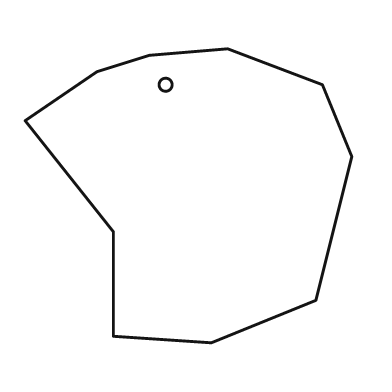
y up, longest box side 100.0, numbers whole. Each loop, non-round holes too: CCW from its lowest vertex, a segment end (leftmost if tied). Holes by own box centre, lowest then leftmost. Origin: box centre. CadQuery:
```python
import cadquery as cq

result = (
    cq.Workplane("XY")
    .moveTo(7.0, -45.0)
    .lineTo(39.0, -32.0)
    .lineTo(50.0, 12.0)
    .lineTo(41.0, 34.0)
    .lineTo(12.0, 45.0)
    .lineTo(-12.0, 43.0)
    .lineTo(-28.0, 38.0)
    .lineTo(-50.0, 23.0)
    .lineTo(-23.0, -11.0)
    .lineTo(-23.0, -43.0)
    .close()
    .moveTo(-7.0, 34.0)
    .circle(2.0)
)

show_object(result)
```